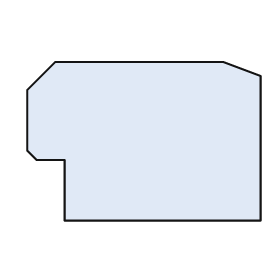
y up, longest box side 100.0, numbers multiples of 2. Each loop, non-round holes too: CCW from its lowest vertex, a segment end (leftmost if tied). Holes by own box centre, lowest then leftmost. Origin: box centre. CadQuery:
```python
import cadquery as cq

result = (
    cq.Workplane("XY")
    .moveTo(-34.0, -34.0)
    .lineTo(50.0, -34.0)
    .lineTo(50.0, 28.0)
    .lineTo(34.0, 34.0)
    .lineTo(-38.0, 34.0)
    .lineTo(-50.0, 22.0)
    .lineTo(-50.0, -4.0)
    .lineTo(-46.0, -8.0)
    .lineTo(-34.0, -8.0)
    .close()
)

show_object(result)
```